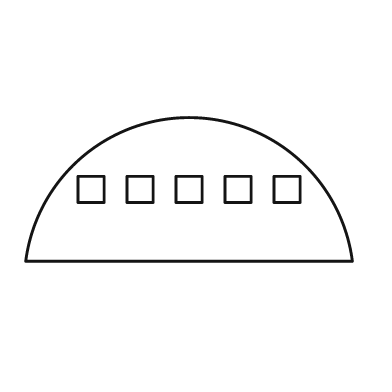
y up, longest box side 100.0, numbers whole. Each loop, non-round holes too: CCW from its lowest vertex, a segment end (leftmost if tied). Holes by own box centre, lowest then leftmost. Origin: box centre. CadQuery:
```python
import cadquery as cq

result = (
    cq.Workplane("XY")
    .moveTo(-50.0, -22.0)
    .lineTo(50.0, -22.0)
    .threePointArc((0.0, 22.0), (-50.0, -22.0))
    .close()
    .moveTo(-34.0, -4.0)
    .lineTo(-26.0, -4.0)
    .lineTo(-26.0, 4.0)
    .lineTo(-34.0, 4.0)
    .close()
    .moveTo(-19.0, -4.0)
    .lineTo(-11.0, -4.0)
    .lineTo(-11.0, 4.0)
    .lineTo(-19.0, 4.0)
    .close()
    .moveTo(-4.0, -4.0)
    .lineTo(4.0, -4.0)
    .lineTo(4.0, 4.0)
    .lineTo(-4.0, 4.0)
    .close()
    .moveTo(11.0, -4.0)
    .lineTo(19.0, -4.0)
    .lineTo(19.0, 4.0)
    .lineTo(11.0, 4.0)
    .close()
    .moveTo(26.0, -4.0)
    .lineTo(34.0, -4.0)
    .lineTo(34.0, 4.0)
    .lineTo(26.0, 4.0)
    .close()
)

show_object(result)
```